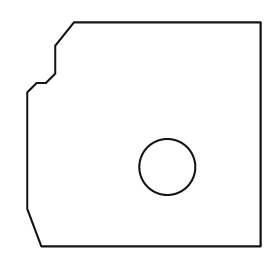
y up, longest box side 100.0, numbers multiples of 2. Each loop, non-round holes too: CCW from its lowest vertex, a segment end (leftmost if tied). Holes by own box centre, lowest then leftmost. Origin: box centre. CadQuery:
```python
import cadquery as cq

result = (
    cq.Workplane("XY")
    .moveTo(-44.0, -48.0)
    .lineTo(50.0, -48.0)
    .lineTo(50.0, 48.0)
    .lineTo(-30.0, 48.0)
    .lineTo(-38.0, 38.0)
    .lineTo(-38.0, 26.0)
    .lineTo(-42.0, 22.0)
    .lineTo(-46.0, 22.0)
    .lineTo(-50.0, 18.0)
    .lineTo(-50.0, -32.0)
    .close()
    .moveTo(10.0, -14.0)
    .circle(12.0)
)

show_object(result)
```